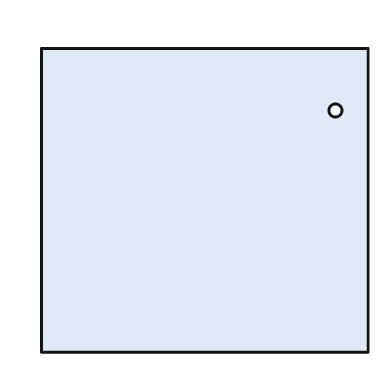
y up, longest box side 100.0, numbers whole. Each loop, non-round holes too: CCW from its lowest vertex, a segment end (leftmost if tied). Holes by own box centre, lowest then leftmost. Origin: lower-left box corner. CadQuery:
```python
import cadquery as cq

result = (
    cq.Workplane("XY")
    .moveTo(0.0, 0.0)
    .lineTo(100.0, 0.0)
    .lineTo(100.0, 93.0)
    .lineTo(0.0, 93.0)
    .close()
    .moveTo(90.0, 74.0)
    .circle(2.0)
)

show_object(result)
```